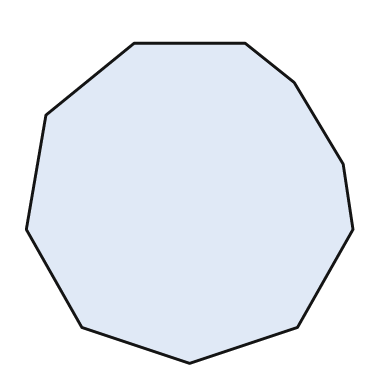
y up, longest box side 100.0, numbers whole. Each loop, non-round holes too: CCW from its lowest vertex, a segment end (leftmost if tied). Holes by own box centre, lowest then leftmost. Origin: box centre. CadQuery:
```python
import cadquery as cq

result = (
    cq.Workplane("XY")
    .moveTo(0.0, -49.0)
    .lineTo(33.0, -38.0)
    .lineTo(50.0, -8.0)
    .lineTo(47.0, 12.0)
    .lineTo(32.0, 37.0)
    .lineTo(17.0, 49.0)
    .lineTo(-17.0, 49.0)
    .lineTo(-44.0, 27.0)
    .lineTo(-50.0, -8.0)
    .lineTo(-33.0, -38.0)
    .close()
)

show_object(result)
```